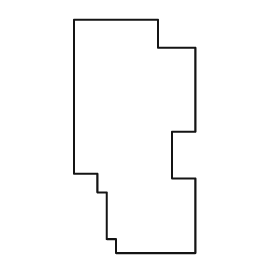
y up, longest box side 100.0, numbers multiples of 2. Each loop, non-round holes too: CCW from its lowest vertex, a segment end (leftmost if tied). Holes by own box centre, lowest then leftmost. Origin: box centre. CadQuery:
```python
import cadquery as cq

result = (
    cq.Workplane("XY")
    .moveTo(-8.0, -50.0)
    .lineTo(26.0, -50.0)
    .lineTo(26.0, -18.0)
    .lineTo(16.0, -18.0)
    .lineTo(16.0, 2.0)
    .lineTo(26.0, 2.0)
    .lineTo(26.0, 38.0)
    .lineTo(10.0, 38.0)
    .lineTo(10.0, 50.0)
    .lineTo(-26.0, 50.0)
    .lineTo(-26.0, -16.0)
    .lineTo(-16.0, -16.0)
    .lineTo(-16.0, -24.0)
    .lineTo(-12.0, -24.0)
    .lineTo(-12.0, -44.0)
    .lineTo(-8.0, -44.0)
    .close()
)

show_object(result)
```